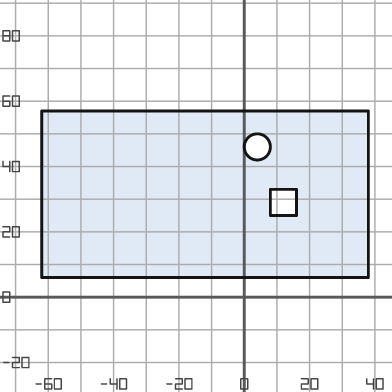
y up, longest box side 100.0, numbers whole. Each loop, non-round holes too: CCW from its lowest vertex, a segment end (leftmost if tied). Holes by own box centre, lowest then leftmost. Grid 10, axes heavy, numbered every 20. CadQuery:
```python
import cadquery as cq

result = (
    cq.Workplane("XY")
    .moveTo(-62.0, 6.0)
    .lineTo(38.0, 6.0)
    .lineTo(38.0, 57.0)
    .lineTo(-62.0, 57.0)
    .close()
    .moveTo(8.0, 25.0)
    .lineTo(16.0, 25.0)
    .lineTo(16.0, 33.0)
    .lineTo(8.0, 33.0)
    .close()
    .moveTo(4.0, 46.0)
    .circle(4.0)
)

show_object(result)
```